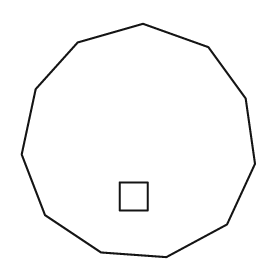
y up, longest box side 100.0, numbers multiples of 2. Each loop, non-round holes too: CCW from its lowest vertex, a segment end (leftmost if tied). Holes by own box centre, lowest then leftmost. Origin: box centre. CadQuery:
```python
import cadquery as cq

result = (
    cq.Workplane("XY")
    .moveTo(12.0, -50.0)
    .lineTo(38.0, -36.0)
    .lineTo(50.0, -10.0)
    .lineTo(46.0, 18.0)
    .lineTo(30.0, 40.0)
    .lineTo(2.0, 50.0)
    .lineTo(-26.0, 42.0)
    .lineTo(-44.0, 22.0)
    .lineTo(-50.0, -6.0)
    .lineTo(-40.0, -32.0)
    .lineTo(-16.0, -48.0)
    .close()
    .moveTo(-8.0, -30.0)
    .lineTo(4.0, -30.0)
    .lineTo(4.0, -18.0)
    .lineTo(-8.0, -18.0)
    .close()
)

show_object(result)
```